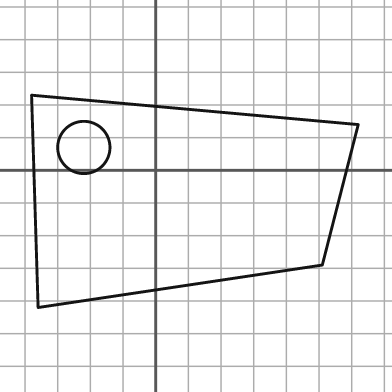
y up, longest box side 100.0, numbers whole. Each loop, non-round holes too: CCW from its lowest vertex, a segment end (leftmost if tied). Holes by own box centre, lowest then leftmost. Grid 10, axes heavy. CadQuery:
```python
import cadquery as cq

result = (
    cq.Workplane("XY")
    .moveTo(-36.0, -42.0)
    .lineTo(51.0, -29.0)
    .lineTo(62.0, 14.0)
    .lineTo(-38.0, 23.0)
    .close()
    .moveTo(-22.0, 7.0)
    .circle(8.0)
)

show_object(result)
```